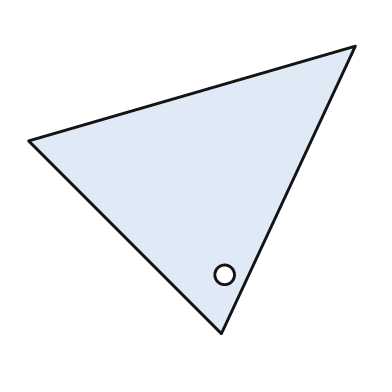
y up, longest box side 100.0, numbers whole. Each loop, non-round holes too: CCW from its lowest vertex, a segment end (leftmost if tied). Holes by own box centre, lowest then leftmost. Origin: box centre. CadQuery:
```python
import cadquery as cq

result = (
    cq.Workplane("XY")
    .moveTo(9.0, -44.0)
    .lineTo(50.0, 44.0)
    .lineTo(-50.0, 15.0)
    .close()
    .moveTo(10.0, -26.0)
    .circle(3.0)
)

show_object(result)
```